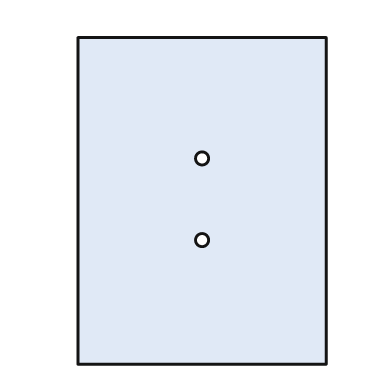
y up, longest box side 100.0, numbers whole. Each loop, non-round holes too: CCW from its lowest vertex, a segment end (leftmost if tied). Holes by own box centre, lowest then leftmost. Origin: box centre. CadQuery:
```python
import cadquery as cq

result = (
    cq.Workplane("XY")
    .moveTo(-38.0, -50.0)
    .lineTo(38.0, -50.0)
    .lineTo(38.0, 50.0)
    .lineTo(-38.0, 50.0)
    .close()
    .moveTo(0.0, -12.0)
    .circle(2.0)
    .moveTo(0.0, 13.0)
    .circle(2.0)
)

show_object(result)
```